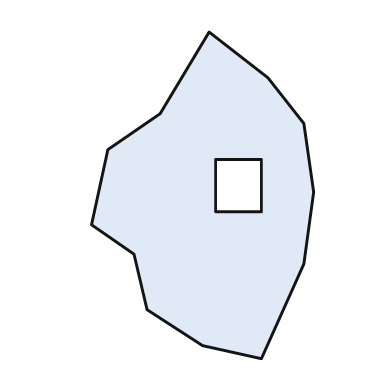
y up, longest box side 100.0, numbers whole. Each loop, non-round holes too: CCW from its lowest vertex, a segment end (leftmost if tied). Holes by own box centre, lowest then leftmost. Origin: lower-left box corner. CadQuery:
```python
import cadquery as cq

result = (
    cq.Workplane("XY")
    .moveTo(52.0, 0.0)
    .lineTo(65.0, 29.0)
    .lineTo(68.0, 51.0)
    .lineTo(65.0, 72.0)
    .lineTo(54.0, 86.0)
    .lineTo(36.0, 100.0)
    .lineTo(21.0, 75.0)
    .lineTo(5.0, 64.0)
    .lineTo(0.0, 41.0)
    .lineTo(13.0, 32.0)
    .lineTo(17.0, 15.0)
    .lineTo(34.0, 4.0)
    .close()
    .moveTo(38.0, 45.0)
    .lineTo(52.0, 45.0)
    .lineTo(52.0, 61.0)
    .lineTo(38.0, 61.0)
    .close()
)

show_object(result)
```